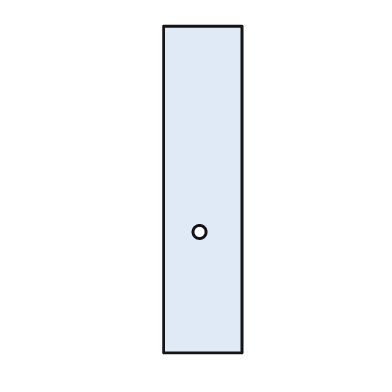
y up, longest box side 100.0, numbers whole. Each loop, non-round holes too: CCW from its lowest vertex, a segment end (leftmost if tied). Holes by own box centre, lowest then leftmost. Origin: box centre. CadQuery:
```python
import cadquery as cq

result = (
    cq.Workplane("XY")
    .moveTo(-12.0, -50.0)
    .lineTo(12.0, -50.0)
    .lineTo(12.0, 50.0)
    .lineTo(-12.0, 50.0)
    .close()
    .moveTo(-1.0, -13.0)
    .circle(2.0)
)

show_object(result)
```